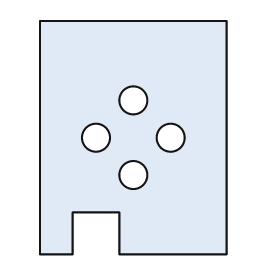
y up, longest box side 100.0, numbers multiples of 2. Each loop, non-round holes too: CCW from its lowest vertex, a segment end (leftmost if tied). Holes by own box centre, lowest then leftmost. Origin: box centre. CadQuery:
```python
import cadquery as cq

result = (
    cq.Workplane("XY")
    .moveTo(-40.0, -50.0)
    .lineTo(-26.0, -50.0)
    .lineTo(-26.0, -32.0)
    .lineTo(-6.0, -32.0)
    .lineTo(-6.0, -50.0)
    .lineTo(40.0, -50.0)
    .lineTo(40.0, 50.0)
    .lineTo(-40.0, 50.0)
    .close()
    .moveTo(0.0, -16.0)
    .circle(6.0)
    .moveTo(-16.0, 0.0)
    .circle(6.0)
    .moveTo(16.0, 0.0)
    .circle(6.0)
    .moveTo(0.0, 16.0)
    .circle(6.0)
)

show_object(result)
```